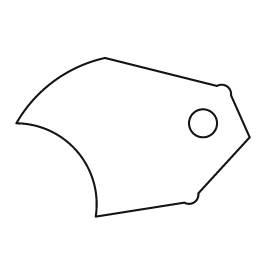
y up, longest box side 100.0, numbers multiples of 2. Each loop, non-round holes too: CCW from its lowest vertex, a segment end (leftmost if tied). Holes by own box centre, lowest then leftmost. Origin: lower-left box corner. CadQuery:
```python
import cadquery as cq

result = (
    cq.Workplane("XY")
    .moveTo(34.0, 0.0)
    .lineTo(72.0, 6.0)
    .threePointArc((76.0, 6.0), (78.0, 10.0))
    .lineTo(100.0, 34.0)
    .lineTo(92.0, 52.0)
    .threePointArc((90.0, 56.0), (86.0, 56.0))
    .lineTo(38.0, 68.0)
    .threePointArc((16.0, 58.0), (0.0, 40.0))
    .threePointArc((26.0, 28.0), (34.0, 0.0))
    .close()
    .moveTo(80.0, 40.0)
    .circle(6.0)
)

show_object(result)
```